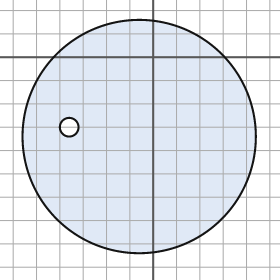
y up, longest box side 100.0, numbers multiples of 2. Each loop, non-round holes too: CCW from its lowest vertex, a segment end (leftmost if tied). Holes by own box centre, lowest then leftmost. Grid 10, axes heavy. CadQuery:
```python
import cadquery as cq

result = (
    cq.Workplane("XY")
    .moveTo(-6.0, -34.0)
    .circle(50.0)
    .moveTo(-36.0, -30.0)
    .circle(4.0)
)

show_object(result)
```